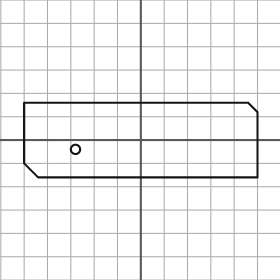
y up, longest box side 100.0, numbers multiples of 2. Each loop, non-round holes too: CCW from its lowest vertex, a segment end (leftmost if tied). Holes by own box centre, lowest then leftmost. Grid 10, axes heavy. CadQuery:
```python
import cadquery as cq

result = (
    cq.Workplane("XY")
    .moveTo(-44.0, -16.0)
    .lineTo(50.0, -16.0)
    .lineTo(50.0, 12.0)
    .lineTo(46.0, 16.0)
    .lineTo(-50.0, 16.0)
    .lineTo(-50.0, -10.0)
    .close()
    .moveTo(-28.0, -4.0)
    .circle(2.0)
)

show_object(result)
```